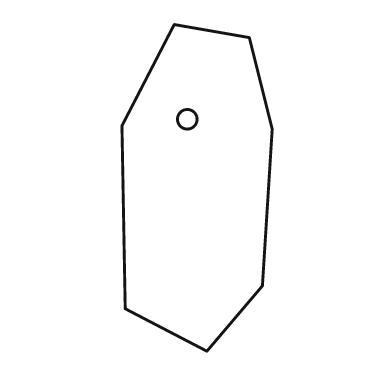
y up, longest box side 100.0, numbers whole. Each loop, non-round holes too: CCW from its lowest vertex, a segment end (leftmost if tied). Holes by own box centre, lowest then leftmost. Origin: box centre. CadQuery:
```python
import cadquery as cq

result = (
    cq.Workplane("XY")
    .moveTo(3.0, -50.0)
    .lineTo(20.0, -30.0)
    .lineTo(23.0, 18.0)
    .lineTo(16.0, 46.0)
    .lineTo(-7.0, 50.0)
    .lineTo(-23.0, 19.0)
    .lineTo(-22.0, -37.0)
    .close()
    .moveTo(-3.0, 21.0)
    .circle(3.0)
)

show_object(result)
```